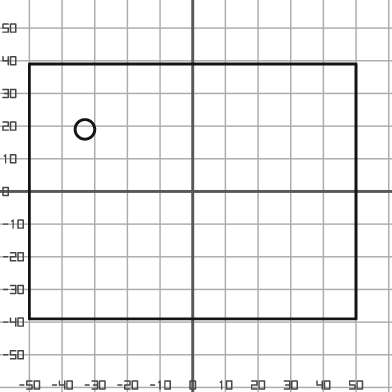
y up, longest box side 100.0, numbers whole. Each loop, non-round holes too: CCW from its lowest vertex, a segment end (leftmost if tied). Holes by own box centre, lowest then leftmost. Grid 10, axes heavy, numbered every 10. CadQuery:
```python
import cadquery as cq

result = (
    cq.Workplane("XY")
    .moveTo(-50.0, -39.0)
    .lineTo(50.0, -39.0)
    .lineTo(50.0, 39.0)
    .lineTo(-50.0, 39.0)
    .close()
    .moveTo(-33.0, 19.0)
    .circle(3.0)
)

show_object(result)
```